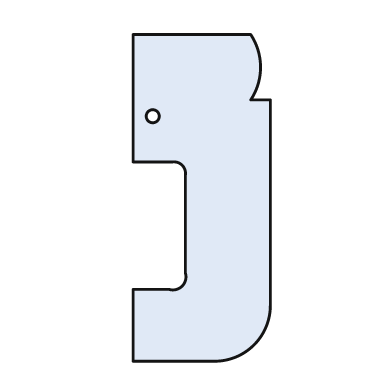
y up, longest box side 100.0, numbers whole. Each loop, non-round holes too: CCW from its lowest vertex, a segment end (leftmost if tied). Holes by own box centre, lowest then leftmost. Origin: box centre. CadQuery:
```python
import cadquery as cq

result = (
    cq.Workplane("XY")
    .moveTo(-21.0, -50.0)
    .lineTo(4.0, -50.0)
    .threePointArc((16.0, -45.0), (21.0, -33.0))
    .lineTo(21.0, 30.0)
    .lineTo(15.0, 30.0)
    .threePointArc((18.0, 40.0), (15.0, 50.0))
    .lineTo(-21.0, 50.0)
    .lineTo(-21.0, 11.0)
    .lineTo(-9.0, 11.0)
    .threePointArc((-6.0, 10.0), (-5.0, 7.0))
    .lineTo(-5.0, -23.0)
    .threePointArc((-6.0, -27.0), (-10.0, -28.0))
    .lineTo(-21.0, -28.0)
    .close()
    .moveTo(-15.0, 25.0)
    .circle(2.0)
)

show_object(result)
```